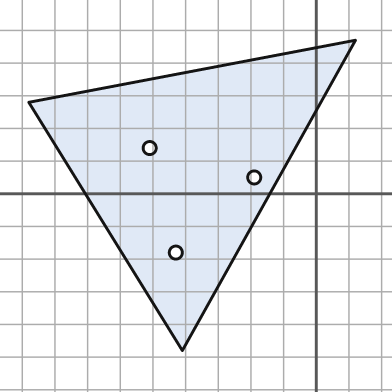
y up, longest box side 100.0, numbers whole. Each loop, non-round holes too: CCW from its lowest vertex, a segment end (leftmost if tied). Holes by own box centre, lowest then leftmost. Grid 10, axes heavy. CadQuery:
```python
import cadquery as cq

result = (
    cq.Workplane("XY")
    .moveTo(-41.0, -48.0)
    .lineTo(12.0, 47.0)
    .lineTo(-88.0, 28.0)
    .close()
    .moveTo(-43.0, -18.0)
    .circle(2.0)
    .moveTo(-19.0, 5.0)
    .circle(2.0)
    .moveTo(-51.0, 14.0)
    .circle(2.0)
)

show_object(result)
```